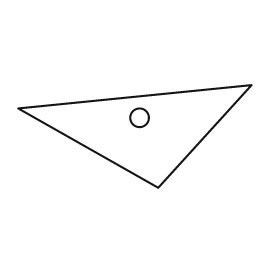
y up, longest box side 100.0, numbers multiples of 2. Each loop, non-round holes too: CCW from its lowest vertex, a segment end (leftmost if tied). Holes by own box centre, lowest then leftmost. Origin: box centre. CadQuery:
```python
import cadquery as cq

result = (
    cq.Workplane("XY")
    .moveTo(10.0, -22.0)
    .lineTo(50.0, 22.0)
    .lineTo(-50.0, 12.0)
    .close()
    .moveTo(2.0, 8.0)
    .circle(4.0)
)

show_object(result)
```